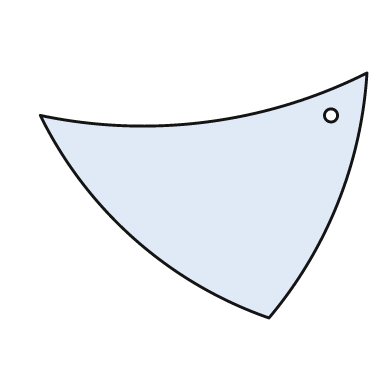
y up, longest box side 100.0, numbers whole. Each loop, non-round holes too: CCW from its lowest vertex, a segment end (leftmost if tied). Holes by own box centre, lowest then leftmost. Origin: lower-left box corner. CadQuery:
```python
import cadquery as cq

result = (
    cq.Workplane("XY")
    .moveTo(70.0, 0.0)
    .threePointArc((91.0, 35.0), (100.0, 75.0))
    .threePointArc((51.0, 60.0), (0.0, 62.0))
    .threePointArc((29.0, 24.0), (70.0, 0.0))
    .close()
    .moveTo(89.0, 62.0)
    .circle(2.0)
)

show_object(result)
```